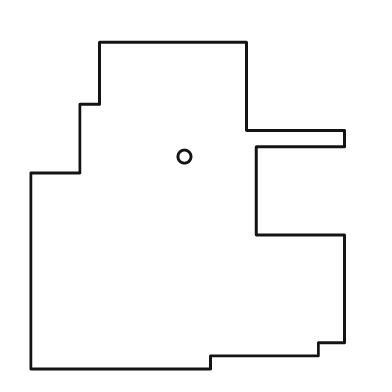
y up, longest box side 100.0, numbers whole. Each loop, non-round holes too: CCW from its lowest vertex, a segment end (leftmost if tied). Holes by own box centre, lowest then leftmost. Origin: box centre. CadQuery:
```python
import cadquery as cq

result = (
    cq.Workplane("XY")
    .moveTo(-48.0, -50.0)
    .lineTo(7.0, -50.0)
    .lineTo(7.0, -46.0)
    .lineTo(40.0, -46.0)
    .lineTo(40.0, -42.0)
    .lineTo(48.0, -42.0)
    .lineTo(48.0, -9.0)
    .lineTo(21.0, -9.0)
    .lineTo(21.0, 18.0)
    .lineTo(48.0, 18.0)
    .lineTo(48.0, 23.0)
    .lineTo(18.0, 23.0)
    .lineTo(18.0, 50.0)
    .lineTo(-27.0, 50.0)
    .lineTo(-27.0, 31.0)
    .lineTo(-33.0, 31.0)
    .lineTo(-33.0, 10.0)
    .lineTo(-48.0, 10.0)
    .close()
    .moveTo(-1.0, 15.0)
    .circle(2.0)
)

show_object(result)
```